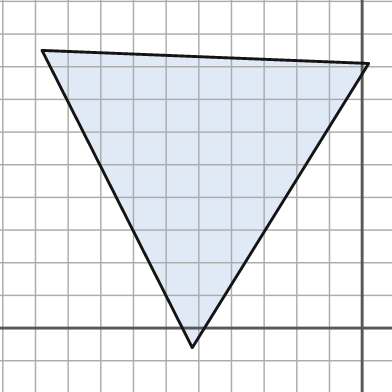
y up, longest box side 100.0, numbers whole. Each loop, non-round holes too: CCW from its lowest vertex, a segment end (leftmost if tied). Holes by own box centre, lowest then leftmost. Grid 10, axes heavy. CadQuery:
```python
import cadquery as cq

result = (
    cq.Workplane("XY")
    .moveTo(-52.0, -6.0)
    .lineTo(2.0, 81.0)
    .lineTo(-98.0, 85.0)
    .close()
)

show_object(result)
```